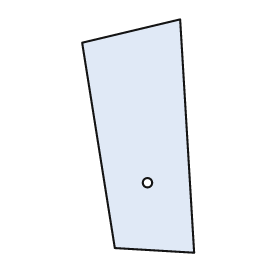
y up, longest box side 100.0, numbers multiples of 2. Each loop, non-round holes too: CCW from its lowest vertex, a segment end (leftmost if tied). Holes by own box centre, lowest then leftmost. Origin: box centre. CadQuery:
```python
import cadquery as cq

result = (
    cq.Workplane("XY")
    .moveTo(24.0, -50.0)
    .lineTo(18.0, 50.0)
    .lineTo(-24.0, 40.0)
    .lineTo(-10.0, -48.0)
    .close()
    .moveTo(4.0, -20.0)
    .circle(2.0)
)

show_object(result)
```